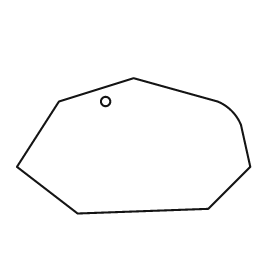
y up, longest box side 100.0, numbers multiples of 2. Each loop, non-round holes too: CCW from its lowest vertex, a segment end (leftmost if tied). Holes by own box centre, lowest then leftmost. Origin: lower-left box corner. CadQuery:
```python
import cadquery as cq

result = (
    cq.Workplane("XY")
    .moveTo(26.0, 0.0)
    .lineTo(82.0, 2.0)
    .lineTo(100.0, 20.0)
    .lineTo(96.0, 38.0)
    .threePointArc((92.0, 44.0), (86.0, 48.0))
    .lineTo(50.0, 58.0)
    .lineTo(18.0, 48.0)
    .lineTo(0.0, 20.0)
    .close()
    .moveTo(38.0, 48.0)
    .circle(2.0)
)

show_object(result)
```